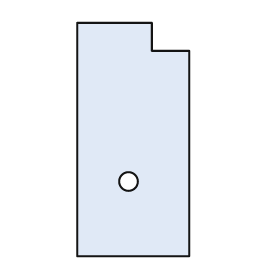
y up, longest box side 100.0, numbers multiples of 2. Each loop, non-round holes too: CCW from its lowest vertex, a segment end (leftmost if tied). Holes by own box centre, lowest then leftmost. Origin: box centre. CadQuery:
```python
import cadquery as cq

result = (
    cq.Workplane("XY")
    .moveTo(-24.0, -50.0)
    .lineTo(24.0, -50.0)
    .lineTo(24.0, 38.0)
    .lineTo(8.0, 38.0)
    .lineTo(8.0, 50.0)
    .lineTo(-24.0, 50.0)
    .close()
    .moveTo(-2.0, -18.0)
    .circle(4.0)
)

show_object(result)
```